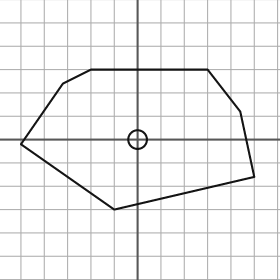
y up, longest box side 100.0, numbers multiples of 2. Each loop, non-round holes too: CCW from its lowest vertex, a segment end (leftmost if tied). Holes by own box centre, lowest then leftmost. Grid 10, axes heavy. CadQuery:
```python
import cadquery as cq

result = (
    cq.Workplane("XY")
    .moveTo(-10.0, -30.0)
    .lineTo(50.0, -16.0)
    .lineTo(44.0, 12.0)
    .lineTo(30.0, 30.0)
    .lineTo(-20.0, 30.0)
    .lineTo(-32.0, 24.0)
    .lineTo(-50.0, -2.0)
    .close()
    .moveTo(0.0, 0.0)
    .circle(4.0)
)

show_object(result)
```